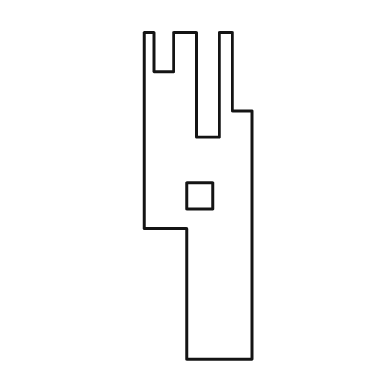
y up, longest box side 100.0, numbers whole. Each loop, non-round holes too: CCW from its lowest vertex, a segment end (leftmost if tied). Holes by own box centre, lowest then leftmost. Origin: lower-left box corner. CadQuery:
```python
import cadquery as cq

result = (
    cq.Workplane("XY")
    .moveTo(13.0, 0.0)
    .lineTo(33.0, 0.0)
    .lineTo(33.0, 76.0)
    .lineTo(27.0, 76.0)
    .lineTo(27.0, 100.0)
    .lineTo(23.0, 100.0)
    .lineTo(23.0, 68.0)
    .lineTo(16.0, 68.0)
    .lineTo(16.0, 100.0)
    .lineTo(9.0, 100.0)
    .lineTo(9.0, 88.0)
    .lineTo(3.0, 88.0)
    .lineTo(3.0, 100.0)
    .lineTo(0.0, 100.0)
    .lineTo(0.0, 40.0)
    .lineTo(13.0, 40.0)
    .close()
    .moveTo(13.0, 46.0)
    .lineTo(21.0, 46.0)
    .lineTo(21.0, 54.0)
    .lineTo(13.0, 54.0)
    .close()
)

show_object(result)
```